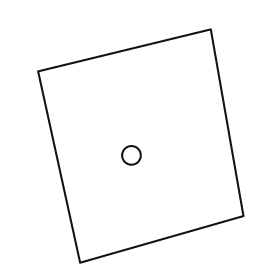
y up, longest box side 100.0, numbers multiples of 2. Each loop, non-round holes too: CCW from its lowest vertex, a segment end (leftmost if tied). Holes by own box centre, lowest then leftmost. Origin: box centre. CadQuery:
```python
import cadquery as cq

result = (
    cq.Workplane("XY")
    .moveTo(-26.0, -50.0)
    .lineTo(44.0, -30.0)
    .lineTo(30.0, 50.0)
    .lineTo(-44.0, 32.0)
    .close()
    .moveTo(-4.0, -4.0)
    .circle(4.0)
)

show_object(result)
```